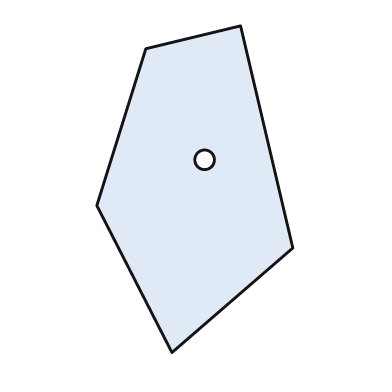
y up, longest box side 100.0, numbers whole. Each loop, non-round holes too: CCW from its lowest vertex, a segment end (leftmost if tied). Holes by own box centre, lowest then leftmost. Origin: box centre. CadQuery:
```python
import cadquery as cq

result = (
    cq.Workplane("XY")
    .moveTo(-7.0, -50.0)
    .lineTo(30.0, -18.0)
    .lineTo(14.0, 50.0)
    .lineTo(-15.0, 43.0)
    .lineTo(-30.0, -5.0)
    .close()
    .moveTo(3.0, 9.0)
    .circle(3.0)
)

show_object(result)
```